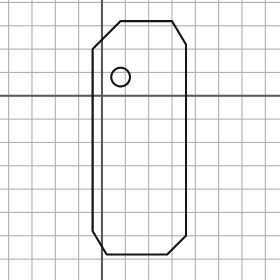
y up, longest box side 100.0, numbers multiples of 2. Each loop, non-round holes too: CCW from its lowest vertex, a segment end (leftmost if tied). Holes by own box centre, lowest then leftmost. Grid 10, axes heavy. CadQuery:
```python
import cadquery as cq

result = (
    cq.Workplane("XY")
    .moveTo(2.0, -68.0)
    .lineTo(28.0, -68.0)
    .lineTo(36.0, -60.0)
    .lineTo(36.0, 22.0)
    .lineTo(30.0, 32.0)
    .lineTo(8.0, 32.0)
    .lineTo(-4.0, 20.0)
    .lineTo(-4.0, -58.0)
    .close()
    .moveTo(8.0, 8.0)
    .circle(4.0)
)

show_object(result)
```